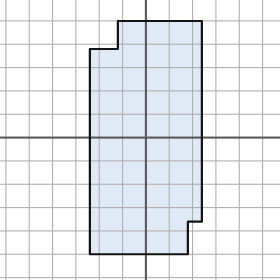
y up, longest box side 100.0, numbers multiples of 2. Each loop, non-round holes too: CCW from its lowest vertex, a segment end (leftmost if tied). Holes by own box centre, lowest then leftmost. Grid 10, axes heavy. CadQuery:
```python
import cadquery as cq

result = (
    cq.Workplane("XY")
    .moveTo(-24.0, -50.0)
    .lineTo(18.0, -50.0)
    .lineTo(18.0, -36.0)
    .lineTo(24.0, -36.0)
    .lineTo(24.0, 50.0)
    .lineTo(-12.0, 50.0)
    .lineTo(-12.0, 38.0)
    .lineTo(-24.0, 38.0)
    .close()
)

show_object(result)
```